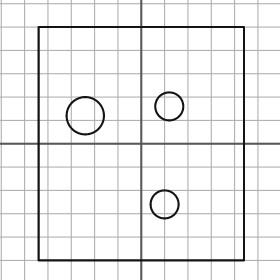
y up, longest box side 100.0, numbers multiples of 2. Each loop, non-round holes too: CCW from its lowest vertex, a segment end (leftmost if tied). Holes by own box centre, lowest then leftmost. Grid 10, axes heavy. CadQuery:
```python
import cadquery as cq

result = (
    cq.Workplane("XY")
    .moveTo(-44.0, -50.0)
    .lineTo(44.0, -50.0)
    .lineTo(44.0, 50.0)
    .lineTo(-44.0, 50.0)
    .close()
    .moveTo(10.0, -26.0)
    .circle(6.0)
    .moveTo(-24.0, 12.0)
    .circle(8.0)
    .moveTo(12.0, 16.0)
    .circle(6.0)
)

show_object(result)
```